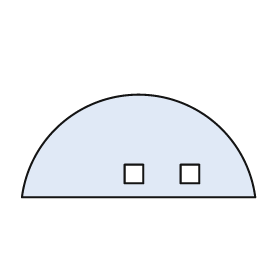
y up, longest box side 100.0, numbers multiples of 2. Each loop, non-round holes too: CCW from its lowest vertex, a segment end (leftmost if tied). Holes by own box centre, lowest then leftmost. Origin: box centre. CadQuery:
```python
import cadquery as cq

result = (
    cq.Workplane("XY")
    .moveTo(-50.0, -22.0)
    .lineTo(50.0, -22.0)
    .threePointArc((0.0, 22.0), (-50.0, -22.0))
    .close()
    .moveTo(-6.0, -16.0)
    .lineTo(2.0, -16.0)
    .lineTo(2.0, -8.0)
    .lineTo(-6.0, -8.0)
    .close()
    .moveTo(18.0, -16.0)
    .lineTo(26.0, -16.0)
    .lineTo(26.0, -8.0)
    .lineTo(18.0, -8.0)
    .close()
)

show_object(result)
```